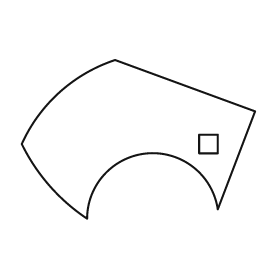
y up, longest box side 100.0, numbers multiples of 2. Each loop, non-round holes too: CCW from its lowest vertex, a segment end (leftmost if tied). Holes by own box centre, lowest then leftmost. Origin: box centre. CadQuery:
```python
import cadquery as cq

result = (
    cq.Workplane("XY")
    .moveTo(-22.0, -34.0)
    .threePointArc((4.0, -6.0), (34.0, -30.0))
    .lineTo(50.0, 12.0)
    .lineTo(-10.0, 34.0)
    .threePointArc((-34.0, 20.0), (-50.0, -2.0))
    .threePointArc((-38.0, -20.0), (-22.0, -34.0))
    .close()
    .moveTo(26.0, -6.0)
    .lineTo(34.0, -6.0)
    .lineTo(34.0, 2.0)
    .lineTo(26.0, 2.0)
    .close()
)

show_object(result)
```